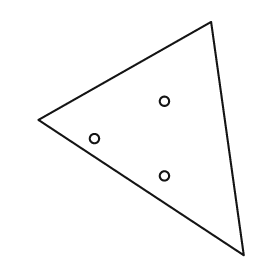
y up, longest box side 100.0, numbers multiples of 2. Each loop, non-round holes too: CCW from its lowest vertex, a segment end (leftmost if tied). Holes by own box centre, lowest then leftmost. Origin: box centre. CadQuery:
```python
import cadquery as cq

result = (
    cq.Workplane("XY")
    .moveTo(44.0, -50.0)
    .lineTo(30.0, 50.0)
    .lineTo(-44.0, 8.0)
    .close()
    .moveTo(10.0, -16.0)
    .circle(2.0)
    .moveTo(-20.0, 0.0)
    .circle(2.0)
    .moveTo(10.0, 16.0)
    .circle(2.0)
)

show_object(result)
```